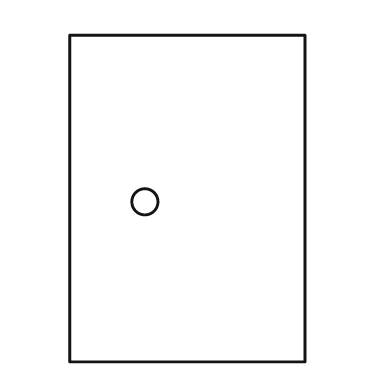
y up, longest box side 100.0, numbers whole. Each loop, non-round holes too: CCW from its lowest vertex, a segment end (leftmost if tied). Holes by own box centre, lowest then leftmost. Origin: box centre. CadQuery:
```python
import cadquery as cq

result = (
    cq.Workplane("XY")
    .moveTo(-36.0, -50.0)
    .lineTo(36.0, -50.0)
    .lineTo(36.0, 50.0)
    .lineTo(-36.0, 50.0)
    .close()
    .moveTo(-13.0, -1.0)
    .circle(4.0)
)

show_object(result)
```